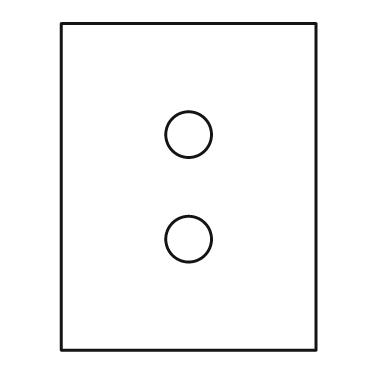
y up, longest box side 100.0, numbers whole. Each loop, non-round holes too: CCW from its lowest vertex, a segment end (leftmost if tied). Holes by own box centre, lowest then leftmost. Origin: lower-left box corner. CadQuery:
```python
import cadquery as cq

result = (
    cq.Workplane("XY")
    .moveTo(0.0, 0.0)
    .lineTo(78.0, 0.0)
    .lineTo(78.0, 100.0)
    .lineTo(0.0, 100.0)
    .close()
    .moveTo(39.0, 34.0)
    .circle(7.0)
    .moveTo(39.0, 66.0)
    .circle(7.0)
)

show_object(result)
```